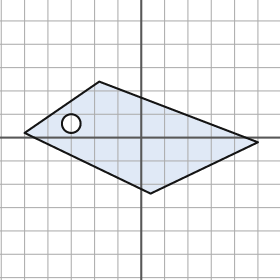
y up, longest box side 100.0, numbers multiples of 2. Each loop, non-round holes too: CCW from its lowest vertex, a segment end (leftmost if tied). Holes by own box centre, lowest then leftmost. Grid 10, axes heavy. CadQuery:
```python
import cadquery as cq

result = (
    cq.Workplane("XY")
    .moveTo(4.0, -24.0)
    .lineTo(50.0, -2.0)
    .lineTo(-18.0, 24.0)
    .lineTo(-50.0, 2.0)
    .close()
    .moveTo(-30.0, 6.0)
    .circle(4.0)
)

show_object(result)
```